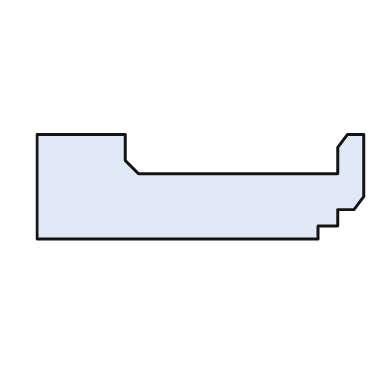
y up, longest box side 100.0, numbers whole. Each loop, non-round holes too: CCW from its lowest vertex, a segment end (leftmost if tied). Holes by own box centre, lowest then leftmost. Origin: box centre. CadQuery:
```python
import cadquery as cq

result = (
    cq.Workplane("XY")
    .moveTo(-50.0, -16.0)
    .lineTo(36.0, -16.0)
    .lineTo(36.0, -12.0)
    .lineTo(42.0, -12.0)
    .lineTo(42.0, -7.0)
    .lineTo(47.0, -7.0)
    .lineTo(50.0, -3.0)
    .lineTo(50.0, 16.0)
    .lineTo(45.0, 16.0)
    .lineTo(42.0, 12.0)
    .lineTo(42.0, 4.0)
    .lineTo(-19.0, 4.0)
    .lineTo(-23.0, 8.0)
    .lineTo(-23.0, 16.0)
    .lineTo(-50.0, 16.0)
    .close()
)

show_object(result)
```